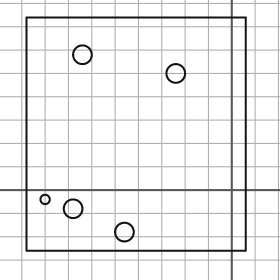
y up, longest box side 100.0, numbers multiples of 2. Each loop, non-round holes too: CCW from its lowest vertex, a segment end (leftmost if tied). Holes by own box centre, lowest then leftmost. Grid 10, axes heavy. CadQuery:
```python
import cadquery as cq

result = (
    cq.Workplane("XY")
    .moveTo(-88.0, -26.0)
    .lineTo(6.0, -26.0)
    .lineTo(6.0, 74.0)
    .lineTo(-88.0, 74.0)
    .close()
    .moveTo(-46.0, -18.0)
    .circle(4.0)
    .moveTo(-68.0, -8.0)
    .circle(4.0)
    .moveTo(-80.0, -4.0)
    .circle(2.0)
    .moveTo(-24.0, 50.0)
    .circle(4.0)
    .moveTo(-64.0, 58.0)
    .circle(4.0)
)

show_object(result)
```